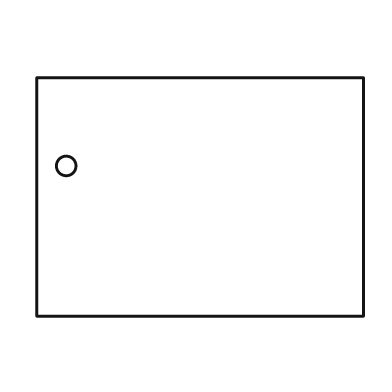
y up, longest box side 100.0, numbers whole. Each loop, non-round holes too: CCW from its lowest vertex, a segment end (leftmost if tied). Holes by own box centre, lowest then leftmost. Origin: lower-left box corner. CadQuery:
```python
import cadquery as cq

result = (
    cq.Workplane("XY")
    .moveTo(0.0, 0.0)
    .lineTo(100.0, 0.0)
    .lineTo(100.0, 73.0)
    .lineTo(0.0, 73.0)
    .close()
    .moveTo(9.0, 46.0)
    .circle(3.0)
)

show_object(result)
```